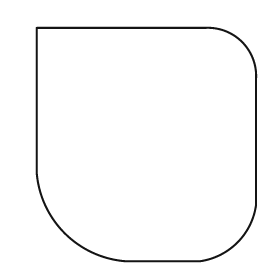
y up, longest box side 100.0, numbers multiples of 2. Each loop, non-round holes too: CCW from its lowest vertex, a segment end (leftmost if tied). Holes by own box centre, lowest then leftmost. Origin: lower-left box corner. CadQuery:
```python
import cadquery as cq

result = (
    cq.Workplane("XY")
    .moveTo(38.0, 0.0)
    .lineTo(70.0, 0.0)
    .threePointArc((86.0, 8.0), (94.0, 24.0))
    .lineTo(94.0, 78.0)
    .threePointArc((88.0, 94.0), (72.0, 100.0))
    .lineTo(0.0, 100.0)
    .lineTo(0.0, 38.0)
    .threePointArc((12.0, 12.0), (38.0, 0.0))
    .close()
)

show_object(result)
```